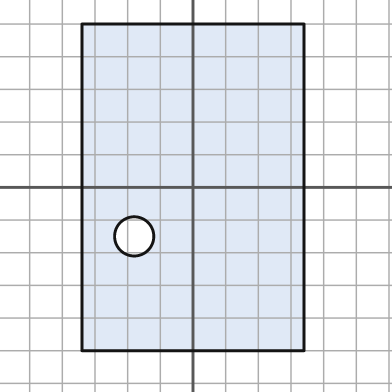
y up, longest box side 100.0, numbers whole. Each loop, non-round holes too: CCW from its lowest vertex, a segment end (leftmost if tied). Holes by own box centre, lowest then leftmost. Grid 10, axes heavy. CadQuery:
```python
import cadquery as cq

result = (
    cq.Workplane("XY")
    .moveTo(-34.0, -50.0)
    .lineTo(34.0, -50.0)
    .lineTo(34.0, 50.0)
    .lineTo(-34.0, 50.0)
    .close()
    .moveTo(-18.0, -15.0)
    .circle(6.0)
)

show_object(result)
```